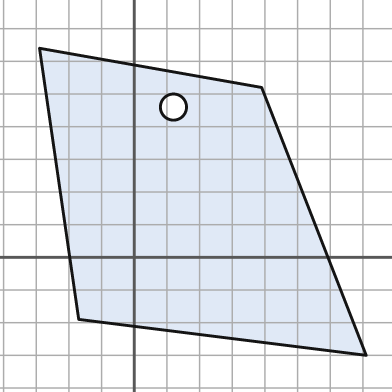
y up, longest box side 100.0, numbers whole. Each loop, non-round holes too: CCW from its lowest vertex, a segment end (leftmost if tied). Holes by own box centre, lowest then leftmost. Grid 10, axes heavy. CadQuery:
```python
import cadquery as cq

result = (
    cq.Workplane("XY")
    .moveTo(71.0, -30.0)
    .lineTo(39.0, 52.0)
    .lineTo(-29.0, 64.0)
    .lineTo(-17.0, -19.0)
    .close()
    .moveTo(12.0, 46.0)
    .circle(4.0)
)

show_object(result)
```